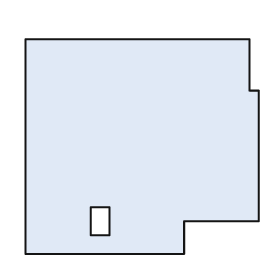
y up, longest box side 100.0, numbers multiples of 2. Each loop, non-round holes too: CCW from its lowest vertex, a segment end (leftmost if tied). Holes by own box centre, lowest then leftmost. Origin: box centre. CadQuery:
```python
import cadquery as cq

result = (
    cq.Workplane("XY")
    .moveTo(-50.0, -46.0)
    .lineTo(18.0, -46.0)
    .lineTo(18.0, -32.0)
    .lineTo(50.0, -32.0)
    .lineTo(50.0, 24.0)
    .lineTo(46.0, 24.0)
    .lineTo(46.0, 46.0)
    .lineTo(-50.0, 46.0)
    .close()
    .moveTo(-22.0, -38.0)
    .lineTo(-14.0, -38.0)
    .lineTo(-14.0, -26.0)
    .lineTo(-22.0, -26.0)
    .close()
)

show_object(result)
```